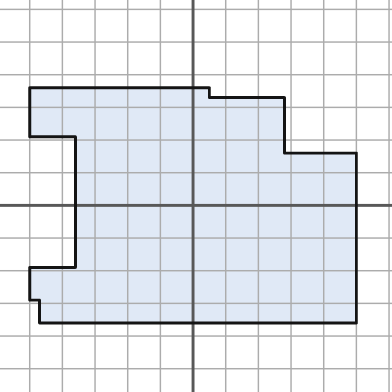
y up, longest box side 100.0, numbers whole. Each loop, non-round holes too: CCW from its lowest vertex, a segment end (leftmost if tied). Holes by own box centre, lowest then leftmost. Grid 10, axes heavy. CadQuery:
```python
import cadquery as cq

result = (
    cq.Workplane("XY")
    .moveTo(-47.0, -36.0)
    .lineTo(50.0, -36.0)
    .lineTo(50.0, 16.0)
    .lineTo(28.0, 16.0)
    .lineTo(28.0, 33.0)
    .lineTo(5.0, 33.0)
    .lineTo(5.0, 36.0)
    .lineTo(-50.0, 36.0)
    .lineTo(-50.0, 21.0)
    .lineTo(-36.0, 21.0)
    .lineTo(-36.0, -19.0)
    .lineTo(-50.0, -19.0)
    .lineTo(-50.0, -29.0)
    .lineTo(-47.0, -29.0)
    .close()
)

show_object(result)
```